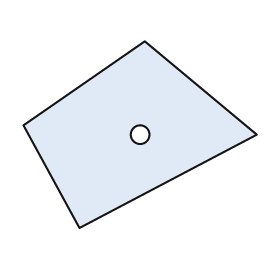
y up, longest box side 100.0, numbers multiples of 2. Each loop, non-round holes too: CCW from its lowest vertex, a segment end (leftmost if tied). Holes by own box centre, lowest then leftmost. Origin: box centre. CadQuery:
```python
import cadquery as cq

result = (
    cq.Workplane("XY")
    .moveTo(-26.0, -40.0)
    .lineTo(50.0, 0.0)
    .lineTo(2.0, 40.0)
    .lineTo(-50.0, 4.0)
    .close()
    .moveTo(0.0, 0.0)
    .circle(4.0)
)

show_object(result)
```